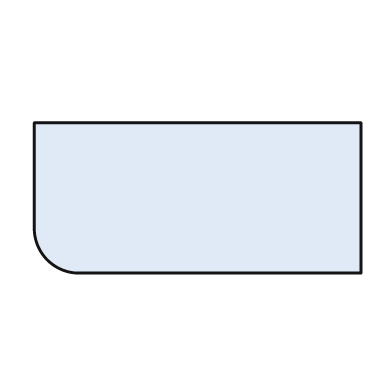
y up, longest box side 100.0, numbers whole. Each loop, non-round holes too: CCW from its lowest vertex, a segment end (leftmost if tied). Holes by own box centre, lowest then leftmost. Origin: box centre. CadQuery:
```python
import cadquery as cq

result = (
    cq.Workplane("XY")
    .moveTo(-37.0, -23.0)
    .lineTo(50.0, -23.0)
    .lineTo(50.0, 23.0)
    .lineTo(-50.0, 23.0)
    .lineTo(-50.0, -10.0)
    .threePointArc((-46.0, -19.0), (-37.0, -23.0))
    .close()
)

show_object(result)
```